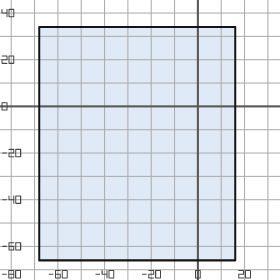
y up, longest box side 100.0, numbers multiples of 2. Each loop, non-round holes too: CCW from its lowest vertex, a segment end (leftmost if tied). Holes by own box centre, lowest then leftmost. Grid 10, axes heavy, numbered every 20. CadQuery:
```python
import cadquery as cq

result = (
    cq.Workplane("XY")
    .moveTo(-68.0, -66.0)
    .lineTo(16.0, -66.0)
    .lineTo(16.0, 34.0)
    .lineTo(-68.0, 34.0)
    .close()
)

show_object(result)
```